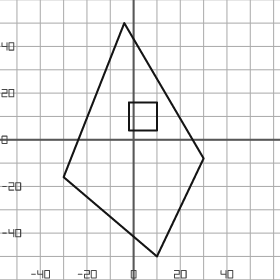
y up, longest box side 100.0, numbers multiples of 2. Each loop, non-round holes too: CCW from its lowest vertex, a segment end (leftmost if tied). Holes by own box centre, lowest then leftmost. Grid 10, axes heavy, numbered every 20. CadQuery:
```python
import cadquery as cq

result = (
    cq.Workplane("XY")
    .moveTo(10.0, -50.0)
    .lineTo(30.0, -8.0)
    .lineTo(-4.0, 50.0)
    .lineTo(-30.0, -16.0)
    .close()
    .moveTo(-2.0, 4.0)
    .lineTo(10.0, 4.0)
    .lineTo(10.0, 16.0)
    .lineTo(-2.0, 16.0)
    .close()
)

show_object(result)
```